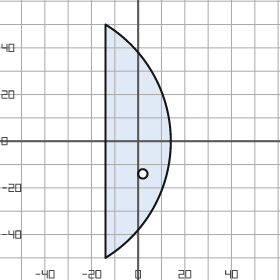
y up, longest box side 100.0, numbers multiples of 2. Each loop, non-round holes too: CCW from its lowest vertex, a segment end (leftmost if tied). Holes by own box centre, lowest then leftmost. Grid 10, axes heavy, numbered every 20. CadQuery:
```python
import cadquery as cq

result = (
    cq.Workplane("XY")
    .moveTo(-14.0, -50.0)
    .threePointArc((14.0, 0.0), (-14.0, 50.0))
    .close()
    .moveTo(2.0, -14.0)
    .circle(2.0)
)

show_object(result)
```